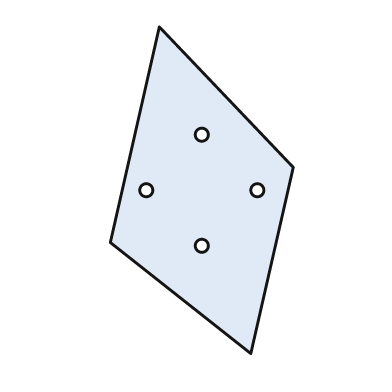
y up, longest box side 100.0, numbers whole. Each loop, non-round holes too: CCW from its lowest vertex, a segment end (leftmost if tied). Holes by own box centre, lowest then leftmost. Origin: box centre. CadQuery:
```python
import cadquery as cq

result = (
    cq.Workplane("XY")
    .moveTo(15.0, -50.0)
    .lineTo(28.0, 7.0)
    .lineTo(-13.0, 50.0)
    .lineTo(-28.0, -16.0)
    .close()
    .moveTo(0.0, -17.0)
    .circle(2.0)
    .moveTo(-17.0, 0.0)
    .circle(2.0)
    .moveTo(17.0, 0.0)
    .circle(2.0)
    .moveTo(0.0, 17.0)
    .circle(2.0)
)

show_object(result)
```